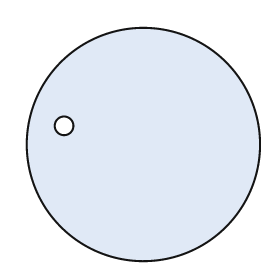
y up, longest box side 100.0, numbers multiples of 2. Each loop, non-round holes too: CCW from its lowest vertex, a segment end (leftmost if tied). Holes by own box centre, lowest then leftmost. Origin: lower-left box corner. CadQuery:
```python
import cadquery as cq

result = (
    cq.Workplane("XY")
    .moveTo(50.0, 50.0)
    .circle(50.0)
    .moveTo(16.0, 58.0)
    .circle(4.0)
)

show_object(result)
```